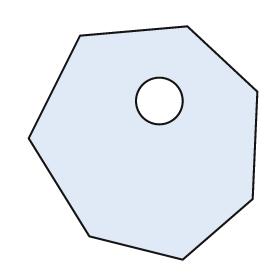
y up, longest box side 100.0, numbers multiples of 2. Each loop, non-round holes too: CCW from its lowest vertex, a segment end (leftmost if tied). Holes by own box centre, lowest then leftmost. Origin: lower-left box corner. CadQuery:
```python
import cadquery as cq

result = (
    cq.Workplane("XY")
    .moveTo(66.0, 0.0)
    .lineTo(96.0, 26.0)
    .lineTo(98.0, 72.0)
    .lineTo(68.0, 100.0)
    .lineTo(22.0, 96.0)
    .lineTo(0.0, 52.0)
    .lineTo(26.0, 10.0)
    .close()
    .moveTo(56.0, 68.0)
    .circle(10.0)
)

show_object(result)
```